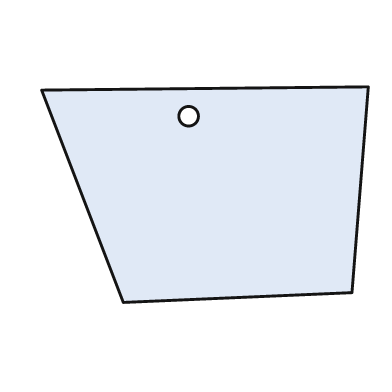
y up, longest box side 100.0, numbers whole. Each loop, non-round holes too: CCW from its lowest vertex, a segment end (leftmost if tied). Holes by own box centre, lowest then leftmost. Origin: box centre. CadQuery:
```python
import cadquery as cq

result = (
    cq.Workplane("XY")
    .moveTo(-25.0, -33.0)
    .lineTo(45.0, -30.0)
    .lineTo(50.0, 33.0)
    .lineTo(-50.0, 32.0)
    .close()
    .moveTo(-5.0, 24.0)
    .circle(3.0)
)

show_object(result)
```